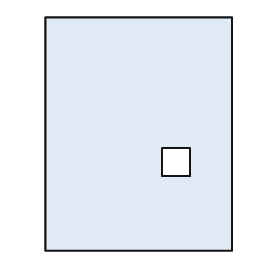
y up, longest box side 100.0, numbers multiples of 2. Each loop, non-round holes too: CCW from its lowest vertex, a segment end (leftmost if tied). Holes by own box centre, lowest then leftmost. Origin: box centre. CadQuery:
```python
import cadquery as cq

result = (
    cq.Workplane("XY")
    .moveTo(-40.0, -50.0)
    .lineTo(40.0, -50.0)
    .lineTo(40.0, 50.0)
    .lineTo(-40.0, 50.0)
    .close()
    .moveTo(10.0, -18.0)
    .lineTo(22.0, -18.0)
    .lineTo(22.0, -6.0)
    .lineTo(10.0, -6.0)
    .close()
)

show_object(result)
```